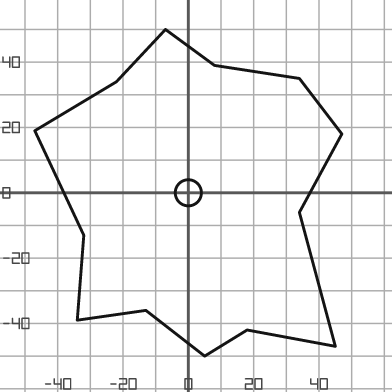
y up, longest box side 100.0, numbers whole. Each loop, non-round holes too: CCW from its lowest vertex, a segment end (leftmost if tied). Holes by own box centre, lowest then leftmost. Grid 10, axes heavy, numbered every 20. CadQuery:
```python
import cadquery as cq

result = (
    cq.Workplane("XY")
    .moveTo(5.0, -50.0)
    .lineTo(18.0, -42.0)
    .lineTo(45.0, -47.0)
    .lineTo(34.0, -6.0)
    .lineTo(47.0, 18.0)
    .lineTo(34.0, 35.0)
    .lineTo(8.0, 39.0)
    .lineTo(-7.0, 50.0)
    .lineTo(-22.0, 34.0)
    .lineTo(-47.0, 19.0)
    .lineTo(-32.0, -13.0)
    .lineTo(-34.0, -39.0)
    .lineTo(-13.0, -36.0)
    .close()
    .moveTo(0.0, 0.0)
    .circle(4.0)
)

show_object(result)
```